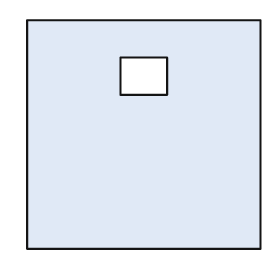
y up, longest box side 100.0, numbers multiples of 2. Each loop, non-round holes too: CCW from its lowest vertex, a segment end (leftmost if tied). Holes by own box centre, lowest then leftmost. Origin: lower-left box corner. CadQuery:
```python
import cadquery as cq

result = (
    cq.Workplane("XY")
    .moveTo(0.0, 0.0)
    .lineTo(100.0, 0.0)
    .lineTo(100.0, 98.0)
    .lineTo(0.0, 98.0)
    .close()
    .moveTo(40.0, 66.0)
    .lineTo(60.0, 66.0)
    .lineTo(60.0, 82.0)
    .lineTo(40.0, 82.0)
    .close()
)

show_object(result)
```